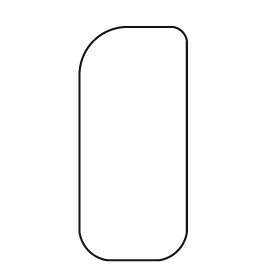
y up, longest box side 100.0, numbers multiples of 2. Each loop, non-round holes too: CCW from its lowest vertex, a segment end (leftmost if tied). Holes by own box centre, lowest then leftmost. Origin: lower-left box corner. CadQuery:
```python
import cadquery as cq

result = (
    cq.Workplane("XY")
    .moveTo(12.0, 0.0)
    .lineTo(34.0, 0.0)
    .threePointArc((42.0, 4.0), (46.0, 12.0))
    .lineTo(46.0, 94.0)
    .threePointArc((44.0, 98.0), (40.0, 100.0))
    .lineTo(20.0, 100.0)
    .threePointArc((6.0, 94.0), (0.0, 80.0))
    .lineTo(0.0, 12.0)
    .threePointArc((4.0, 4.0), (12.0, 0.0))
    .close()
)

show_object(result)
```